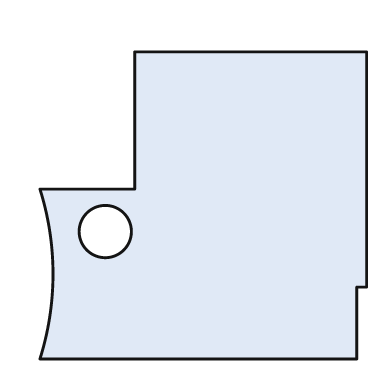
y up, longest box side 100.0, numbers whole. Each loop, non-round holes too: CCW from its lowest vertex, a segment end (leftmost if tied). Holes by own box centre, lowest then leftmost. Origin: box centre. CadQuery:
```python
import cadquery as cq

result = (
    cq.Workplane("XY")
    .moveTo(-50.0, -47.0)
    .lineTo(47.0, -47.0)
    .lineTo(47.0, -25.0)
    .lineTo(50.0, -25.0)
    .lineTo(50.0, 47.0)
    .lineTo(-21.0, 47.0)
    .lineTo(-21.0, 5.0)
    .lineTo(-50.0, 5.0)
    .threePointArc((-46.0, -21.0), (-50.0, -47.0))
    .close()
    .moveTo(-30.0, -8.0)
    .circle(8.0)
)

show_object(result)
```